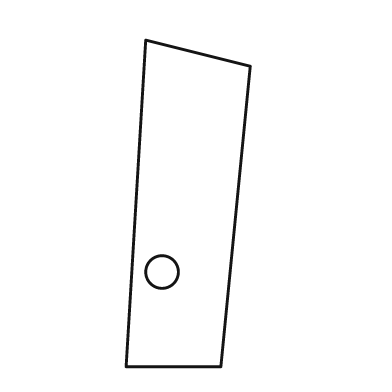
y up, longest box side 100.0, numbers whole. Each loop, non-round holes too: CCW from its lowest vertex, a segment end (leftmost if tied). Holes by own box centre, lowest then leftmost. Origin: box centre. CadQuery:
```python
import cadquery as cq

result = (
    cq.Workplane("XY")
    .moveTo(-19.0, -50.0)
    .lineTo(10.0, -50.0)
    .lineTo(19.0, 42.0)
    .lineTo(-13.0, 50.0)
    .close()
    .moveTo(-8.0, -21.0)
    .circle(5.0)
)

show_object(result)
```